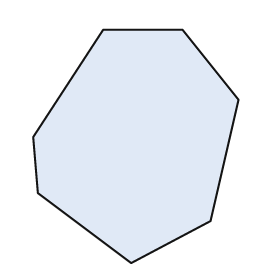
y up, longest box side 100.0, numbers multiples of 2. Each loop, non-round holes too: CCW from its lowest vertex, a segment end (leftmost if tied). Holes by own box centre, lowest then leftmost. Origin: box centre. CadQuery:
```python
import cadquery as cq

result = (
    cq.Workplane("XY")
    .moveTo(-2.0, -50.0)
    .lineTo(32.0, -32.0)
    .lineTo(44.0, 20.0)
    .lineTo(20.0, 50.0)
    .lineTo(-14.0, 50.0)
    .lineTo(-44.0, 4.0)
    .lineTo(-42.0, -20.0)
    .close()
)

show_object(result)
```